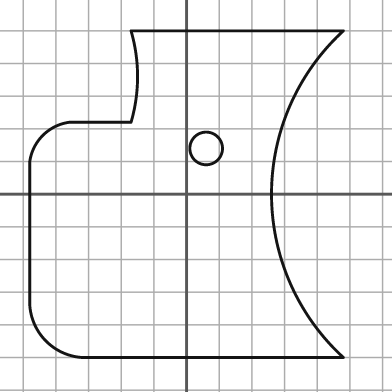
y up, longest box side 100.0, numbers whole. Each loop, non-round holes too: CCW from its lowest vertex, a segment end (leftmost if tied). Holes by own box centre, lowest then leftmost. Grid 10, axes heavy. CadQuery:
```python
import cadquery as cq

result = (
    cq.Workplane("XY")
    .moveTo(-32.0, -50.0)
    .lineTo(48.0, -50.0)
    .threePointArc((26.0, 0.0), (48.0, 50.0))
    .lineTo(-17.0, 50.0)
    .threePointArc((-15.0, 36.0), (-17.0, 22.0))
    .lineTo(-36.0, 22.0)
    .threePointArc((-44.0, 18.0), (-48.0, 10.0))
    .lineTo(-48.0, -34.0)
    .threePointArc((-43.0, -45.0), (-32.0, -50.0))
    .close()
    .moveTo(6.0, 14.0)
    .circle(5.0)
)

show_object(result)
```